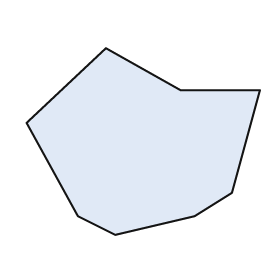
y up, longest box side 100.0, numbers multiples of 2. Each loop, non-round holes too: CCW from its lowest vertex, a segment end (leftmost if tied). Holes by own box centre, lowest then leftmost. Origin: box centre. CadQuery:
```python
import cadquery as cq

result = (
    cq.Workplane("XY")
    .moveTo(-12.0, -40.0)
    .lineTo(22.0, -32.0)
    .lineTo(38.0, -22.0)
    .lineTo(50.0, 22.0)
    .lineTo(16.0, 22.0)
    .lineTo(-16.0, 40.0)
    .lineTo(-50.0, 8.0)
    .lineTo(-28.0, -32.0)
    .close()
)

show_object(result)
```